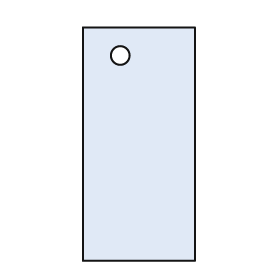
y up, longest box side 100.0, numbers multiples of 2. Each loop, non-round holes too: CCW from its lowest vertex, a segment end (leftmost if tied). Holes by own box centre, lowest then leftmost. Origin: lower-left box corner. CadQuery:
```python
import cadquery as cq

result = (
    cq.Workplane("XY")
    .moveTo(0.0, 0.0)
    .lineTo(48.0, 0.0)
    .lineTo(48.0, 100.0)
    .lineTo(0.0, 100.0)
    .close()
    .moveTo(16.0, 88.0)
    .circle(4.0)
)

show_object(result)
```